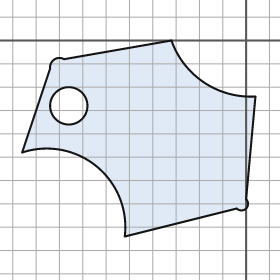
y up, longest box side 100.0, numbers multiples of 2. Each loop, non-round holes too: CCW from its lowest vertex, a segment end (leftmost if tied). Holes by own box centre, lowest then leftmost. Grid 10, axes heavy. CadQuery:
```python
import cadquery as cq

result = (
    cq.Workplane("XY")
    .moveTo(-52.0, -84.0)
    .lineTo(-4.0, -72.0)
    .threePointArc((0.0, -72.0), (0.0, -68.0))
    .lineTo(4.0, -24.0)
    .threePointArc((-18.0, -18.0), (-32.0, 0.0))
    .lineTo(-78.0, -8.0)
    .threePointArc((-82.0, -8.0), (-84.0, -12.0))
    .lineTo(-96.0, -48.0)
    .threePointArc((-64.0, -54.0), (-52.0, -84.0))
    .close()
    .moveTo(-76.0, -28.0)
    .circle(8.0)
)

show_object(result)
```